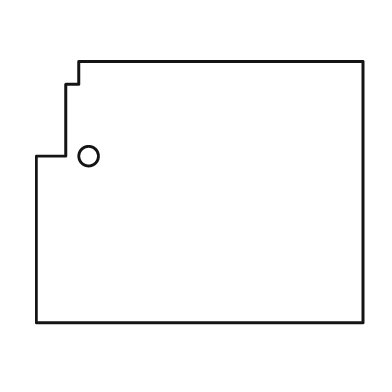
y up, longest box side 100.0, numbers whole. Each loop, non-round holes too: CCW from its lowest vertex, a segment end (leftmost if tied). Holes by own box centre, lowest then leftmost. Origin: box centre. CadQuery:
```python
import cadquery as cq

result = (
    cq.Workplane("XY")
    .moveTo(-50.0, -40.0)
    .lineTo(50.0, -40.0)
    .lineTo(50.0, 40.0)
    .lineTo(-37.0, 40.0)
    .lineTo(-37.0, 33.0)
    .lineTo(-41.0, 33.0)
    .lineTo(-41.0, 11.0)
    .lineTo(-50.0, 11.0)
    .close()
    .moveTo(-34.0, 11.0)
    .circle(3.0)
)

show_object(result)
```